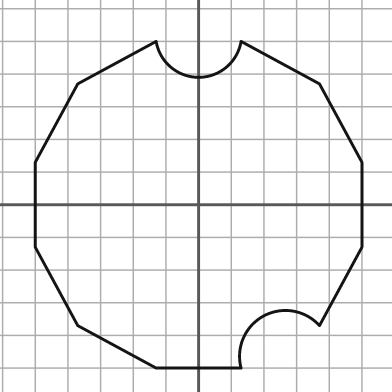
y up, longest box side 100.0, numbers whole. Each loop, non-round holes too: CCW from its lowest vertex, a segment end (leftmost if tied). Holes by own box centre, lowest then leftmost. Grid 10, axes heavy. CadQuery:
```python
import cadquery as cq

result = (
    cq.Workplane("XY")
    .moveTo(-13.0, -50.0)
    .lineTo(13.0, -50.0)
    .threePointArc((20.0, -34.0), (37.0, -37.0))
    .lineTo(50.0, -13.0)
    .lineTo(50.0, 13.0)
    .lineTo(37.0, 37.0)
    .lineTo(13.0, 50.0)
    .threePointArc((0.0, 39.0), (-13.0, 50.0))
    .lineTo(-37.0, 37.0)
    .lineTo(-50.0, 13.0)
    .lineTo(-50.0, -13.0)
    .lineTo(-37.0, -37.0)
    .close()
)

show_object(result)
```